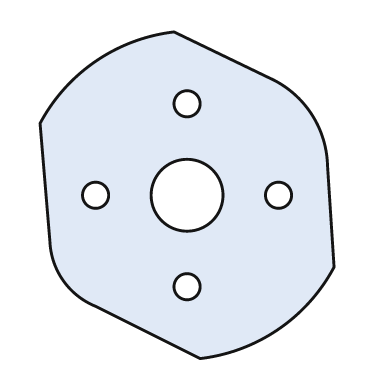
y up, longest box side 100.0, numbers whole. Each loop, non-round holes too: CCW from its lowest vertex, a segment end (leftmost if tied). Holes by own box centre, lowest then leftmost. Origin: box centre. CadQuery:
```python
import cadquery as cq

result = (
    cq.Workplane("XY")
    .moveTo(4.0, -50.0)
    .threePointArc((28.0, -41.0), (45.0, -22.0))
    .lineTo(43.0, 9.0)
    .threePointArc((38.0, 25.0), (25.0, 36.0))
    .lineTo(-4.0, 50.0)
    .threePointArc((-28.0, 41.0), (-45.0, 22.0))
    .lineTo(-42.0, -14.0)
    .threePointArc((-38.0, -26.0), (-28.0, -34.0))
    .close()
    .moveTo(0.0, -28.0)
    .circle(4.0)
    .moveTo(-28.0, 0.0)
    .circle(4.0)
    .moveTo(0.0, 0.0)
    .circle(11.0)
    .moveTo(28.0, 0.0)
    .circle(4.0)
    .moveTo(0.0, 28.0)
    .circle(4.0)
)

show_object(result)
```